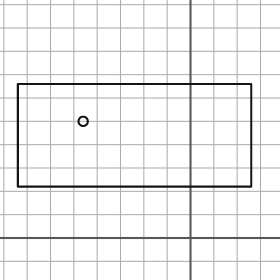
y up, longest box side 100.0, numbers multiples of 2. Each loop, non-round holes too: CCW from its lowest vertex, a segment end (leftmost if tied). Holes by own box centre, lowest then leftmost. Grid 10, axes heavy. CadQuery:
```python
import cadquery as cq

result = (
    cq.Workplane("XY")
    .moveTo(-74.0, 22.0)
    .lineTo(26.0, 22.0)
    .lineTo(26.0, 66.0)
    .lineTo(-74.0, 66.0)
    .close()
    .moveTo(-46.0, 50.0)
    .circle(2.0)
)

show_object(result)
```